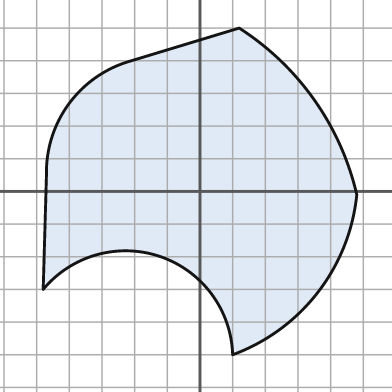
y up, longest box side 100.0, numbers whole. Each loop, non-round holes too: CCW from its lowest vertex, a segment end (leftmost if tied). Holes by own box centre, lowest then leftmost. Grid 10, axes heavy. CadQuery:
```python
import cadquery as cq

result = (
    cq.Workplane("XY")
    .moveTo(10.0, -50.0)
    .threePointArc((36.0, -31.0), (48.0, -1.0))
    .threePointArc((35.0, 28.0), (12.0, 50.0))
    .lineTo(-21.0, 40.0)
    .threePointArc((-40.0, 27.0), (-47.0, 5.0))
    .lineTo(-48.0, -30.0)
    .threePointArc((-12.0, -20.0), (10.0, -50.0))
    .close()
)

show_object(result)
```